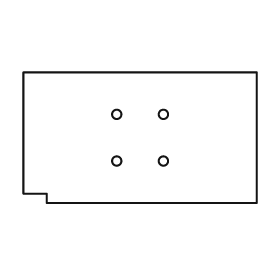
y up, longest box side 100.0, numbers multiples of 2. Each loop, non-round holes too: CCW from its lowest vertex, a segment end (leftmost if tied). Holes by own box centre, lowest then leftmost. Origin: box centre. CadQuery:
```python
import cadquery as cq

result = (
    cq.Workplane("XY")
    .moveTo(-40.0, -28.0)
    .lineTo(50.0, -28.0)
    .lineTo(50.0, 28.0)
    .lineTo(-50.0, 28.0)
    .lineTo(-50.0, -24.0)
    .lineTo(-40.0, -24.0)
    .close()
    .moveTo(-10.0, -10.0)
    .circle(2.0)
    .moveTo(10.0, -10.0)
    .circle(2.0)
    .moveTo(-10.0, 10.0)
    .circle(2.0)
    .moveTo(10.0, 10.0)
    .circle(2.0)
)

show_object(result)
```